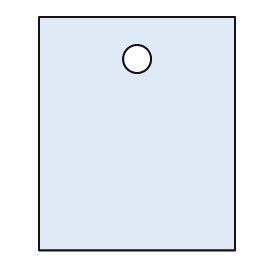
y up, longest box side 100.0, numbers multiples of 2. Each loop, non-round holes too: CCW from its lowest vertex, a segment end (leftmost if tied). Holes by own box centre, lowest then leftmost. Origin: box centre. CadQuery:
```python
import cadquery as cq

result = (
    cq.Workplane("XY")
    .moveTo(-42.0, -50.0)
    .lineTo(42.0, -50.0)
    .lineTo(42.0, 50.0)
    .lineTo(-42.0, 50.0)
    .close()
    .moveTo(0.0, 32.0)
    .circle(6.0)
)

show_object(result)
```